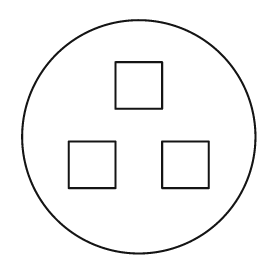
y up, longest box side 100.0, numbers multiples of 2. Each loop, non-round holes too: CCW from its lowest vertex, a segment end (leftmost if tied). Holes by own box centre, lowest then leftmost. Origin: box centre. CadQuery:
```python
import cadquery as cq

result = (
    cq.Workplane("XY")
    .moveTo(0.0, 0.0)
    .circle(50.0)
    .moveTo(-30.0, -22.0)
    .lineTo(-10.0, -22.0)
    .lineTo(-10.0, -2.0)
    .lineTo(-30.0, -2.0)
    .close()
    .moveTo(10.0, -22.0)
    .lineTo(30.0, -22.0)
    .lineTo(30.0, -2.0)
    .lineTo(10.0, -2.0)
    .close()
    .moveTo(-10.0, 12.0)
    .lineTo(10.0, 12.0)
    .lineTo(10.0, 32.0)
    .lineTo(-10.0, 32.0)
    .close()
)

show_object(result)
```